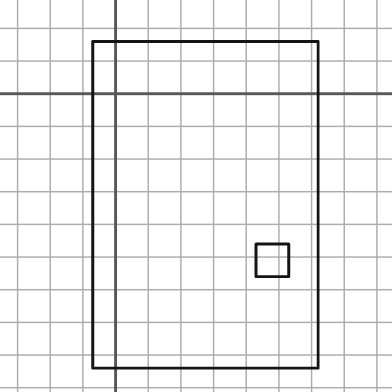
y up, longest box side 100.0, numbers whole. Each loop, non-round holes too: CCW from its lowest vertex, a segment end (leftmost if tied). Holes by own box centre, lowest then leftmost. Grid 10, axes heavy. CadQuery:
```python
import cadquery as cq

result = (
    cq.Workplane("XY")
    .moveTo(-7.0, -84.0)
    .lineTo(62.0, -84.0)
    .lineTo(62.0, 16.0)
    .lineTo(-7.0, 16.0)
    .close()
    .moveTo(43.0, -56.0)
    .lineTo(53.0, -56.0)
    .lineTo(53.0, -46.0)
    .lineTo(43.0, -46.0)
    .close()
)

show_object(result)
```